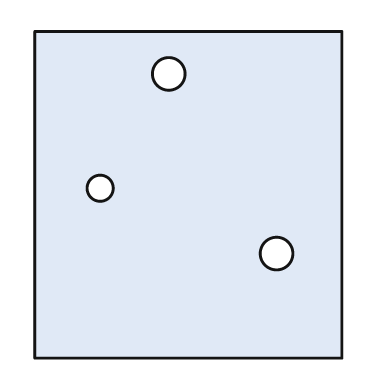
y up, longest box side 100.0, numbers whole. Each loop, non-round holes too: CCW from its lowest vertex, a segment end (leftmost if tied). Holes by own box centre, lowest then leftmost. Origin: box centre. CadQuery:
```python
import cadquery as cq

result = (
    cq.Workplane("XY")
    .moveTo(-47.0, -50.0)
    .lineTo(47.0, -50.0)
    .lineTo(47.0, 50.0)
    .lineTo(-47.0, 50.0)
    .close()
    .moveTo(27.0, -18.0)
    .circle(5.0)
    .moveTo(-27.0, 2.0)
    .circle(4.0)
    .moveTo(-6.0, 37.0)
    .circle(5.0)
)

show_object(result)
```